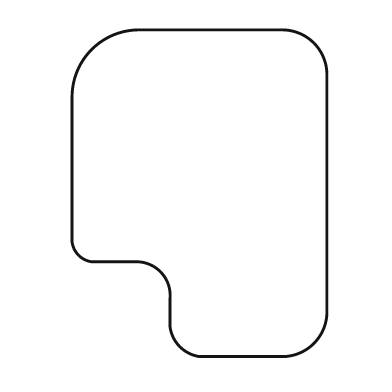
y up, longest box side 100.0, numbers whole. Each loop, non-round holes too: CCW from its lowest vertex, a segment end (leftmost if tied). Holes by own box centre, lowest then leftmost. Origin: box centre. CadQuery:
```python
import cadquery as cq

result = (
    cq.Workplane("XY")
    .moveTo(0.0, -50.0)
    .lineTo(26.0, -50.0)
    .threePointArc((35.0, -46.0), (39.0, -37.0))
    .lineTo(39.0, 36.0)
    .threePointArc((35.0, 46.0), (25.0, 50.0))
    .lineTo(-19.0, 50.0)
    .threePointArc((-33.0, 44.0), (-39.0, 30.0))
    .lineTo(-39.0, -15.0)
    .threePointArc((-37.0, -19.0), (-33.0, -21.0))
    .lineTo(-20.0, -21.0)
    .threePointArc((-12.0, -24.0), (-9.0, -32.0))
    .lineTo(-9.0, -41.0)
    .threePointArc((-6.0, -47.0), (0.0, -50.0))
    .close()
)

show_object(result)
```